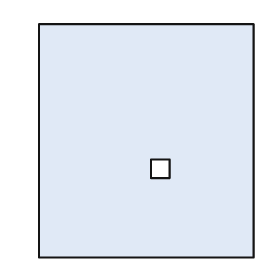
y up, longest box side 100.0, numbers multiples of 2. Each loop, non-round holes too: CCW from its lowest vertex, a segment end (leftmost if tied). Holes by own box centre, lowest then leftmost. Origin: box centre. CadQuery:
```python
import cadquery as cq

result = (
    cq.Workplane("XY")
    .moveTo(-46.0, -50.0)
    .lineTo(46.0, -50.0)
    .lineTo(46.0, 50.0)
    .lineTo(-46.0, 50.0)
    .close()
    .moveTo(2.0, -16.0)
    .lineTo(10.0, -16.0)
    .lineTo(10.0, -8.0)
    .lineTo(2.0, -8.0)
    .close()
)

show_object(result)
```